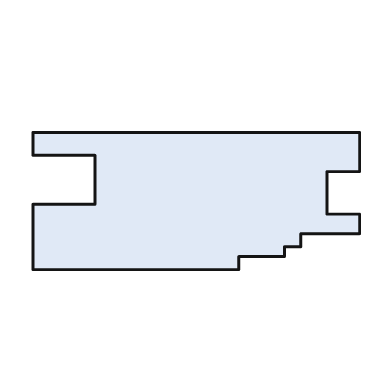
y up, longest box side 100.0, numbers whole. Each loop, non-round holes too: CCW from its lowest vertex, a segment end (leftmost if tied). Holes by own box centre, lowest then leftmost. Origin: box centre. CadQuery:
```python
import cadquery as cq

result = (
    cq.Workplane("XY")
    .moveTo(-50.0, -21.0)
    .lineTo(13.0, -21.0)
    .lineTo(13.0, -17.0)
    .lineTo(27.0, -17.0)
    .lineTo(27.0, -14.0)
    .lineTo(32.0, -14.0)
    .lineTo(32.0, -10.0)
    .lineTo(50.0, -10.0)
    .lineTo(50.0, -4.0)
    .lineTo(40.0, -4.0)
    .lineTo(40.0, 9.0)
    .lineTo(50.0, 9.0)
    .lineTo(50.0, 21.0)
    .lineTo(-50.0, 21.0)
    .lineTo(-50.0, 14.0)
    .lineTo(-31.0, 14.0)
    .lineTo(-31.0, -1.0)
    .lineTo(-50.0, -1.0)
    .close()
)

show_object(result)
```